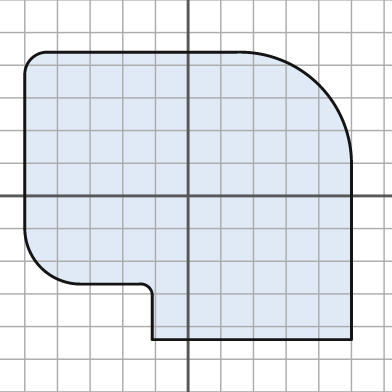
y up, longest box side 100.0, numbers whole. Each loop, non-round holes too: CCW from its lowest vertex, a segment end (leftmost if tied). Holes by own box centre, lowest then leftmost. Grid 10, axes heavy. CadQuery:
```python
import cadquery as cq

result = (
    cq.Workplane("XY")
    .moveTo(-11.0, -44.0)
    .lineTo(50.0, -44.0)
    .lineTo(50.0, 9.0)
    .threePointArc((40.0, 34.0), (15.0, 44.0))
    .lineTo(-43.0, 44.0)
    .threePointArc((-48.0, 42.0), (-50.0, 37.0))
    .lineTo(-50.0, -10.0)
    .threePointArc((-45.0, -22.0), (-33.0, -27.0))
    .lineTo(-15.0, -27.0)
    .threePointArc((-12.0, -28.0), (-11.0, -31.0))
    .close()
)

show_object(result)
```